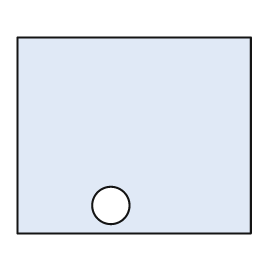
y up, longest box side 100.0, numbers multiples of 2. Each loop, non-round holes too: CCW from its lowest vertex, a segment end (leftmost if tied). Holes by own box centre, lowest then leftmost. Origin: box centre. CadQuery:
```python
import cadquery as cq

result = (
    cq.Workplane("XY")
    .moveTo(-50.0, -42.0)
    .lineTo(50.0, -42.0)
    .lineTo(50.0, 42.0)
    .lineTo(-50.0, 42.0)
    .close()
    .moveTo(-10.0, -30.0)
    .circle(8.0)
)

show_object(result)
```